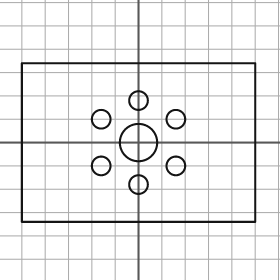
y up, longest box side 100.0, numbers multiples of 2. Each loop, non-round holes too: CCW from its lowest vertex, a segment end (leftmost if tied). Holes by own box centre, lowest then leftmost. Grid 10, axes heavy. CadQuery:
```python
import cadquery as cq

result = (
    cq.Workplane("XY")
    .moveTo(-50.0, -34.0)
    .lineTo(50.0, -34.0)
    .lineTo(50.0, 34.0)
    .lineTo(-50.0, 34.0)
    .close()
    .moveTo(0.0, -18.0)
    .circle(4.0)
    .moveTo(-16.0, -10.0)
    .circle(4.0)
    .moveTo(16.0, -10.0)
    .circle(4.0)
    .moveTo(0.0, 0.0)
    .circle(8.0)
    .moveTo(-16.0, 10.0)
    .circle(4.0)
    .moveTo(16.0, 10.0)
    .circle(4.0)
    .moveTo(0.0, 18.0)
    .circle(4.0)
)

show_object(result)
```